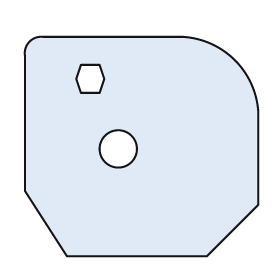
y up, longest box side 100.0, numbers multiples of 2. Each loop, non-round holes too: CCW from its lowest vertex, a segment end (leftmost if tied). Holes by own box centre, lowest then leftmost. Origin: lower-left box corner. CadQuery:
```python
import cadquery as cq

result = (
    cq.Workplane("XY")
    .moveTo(18.0, 0.0)
    .lineTo(78.0, 0.0)
    .lineTo(100.0, 22.0)
    .lineTo(100.0, 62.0)
    .threePointArc((90.0, 84.0), (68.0, 94.0))
    .lineTo(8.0, 94.0)
    .threePointArc((2.0, 92.0), (0.0, 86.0))
    .lineTo(0.0, 28.0)
    .close()
    .moveTo(40.0, 46.0)
    .circle(8.0)
    .moveTo(24.0, 70.0)
    .lineTo(32.0, 70.0)
    .lineTo(34.0, 76.0)
    .lineTo(32.0, 82.0)
    .lineTo(24.0, 82.0)
    .lineTo(22.0, 76.0)
    .close()
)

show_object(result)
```